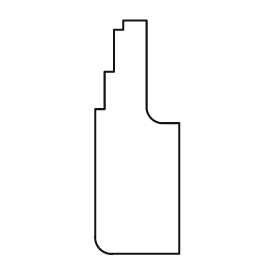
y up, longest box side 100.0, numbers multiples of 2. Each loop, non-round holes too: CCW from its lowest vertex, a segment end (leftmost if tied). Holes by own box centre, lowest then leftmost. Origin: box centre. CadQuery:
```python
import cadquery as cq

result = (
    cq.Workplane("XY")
    .moveTo(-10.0, -50.0)
    .lineTo(18.0, -50.0)
    .lineTo(18.0, 6.0)
    .lineTo(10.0, 6.0)
    .threePointArc((6.0, 8.0), (4.0, 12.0))
    .lineTo(4.0, 50.0)
    .lineTo(-6.0, 50.0)
    .lineTo(-6.0, 46.0)
    .lineTo(-10.0, 46.0)
    .lineTo(-10.0, 28.0)
    .lineTo(-14.0, 28.0)
    .lineTo(-14.0, 12.0)
    .lineTo(-18.0, 12.0)
    .lineTo(-18.0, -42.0)
    .threePointArc((-16.0, -48.0), (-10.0, -50.0))
    .close()
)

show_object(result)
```